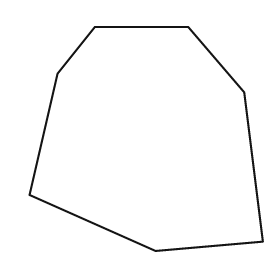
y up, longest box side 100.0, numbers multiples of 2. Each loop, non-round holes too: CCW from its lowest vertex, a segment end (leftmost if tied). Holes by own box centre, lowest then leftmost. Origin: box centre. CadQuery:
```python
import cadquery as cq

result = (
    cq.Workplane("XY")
    .moveTo(4.0, -48.0)
    .lineTo(50.0, -44.0)
    .lineTo(42.0, 20.0)
    .lineTo(18.0, 48.0)
    .lineTo(-22.0, 48.0)
    .lineTo(-38.0, 28.0)
    .lineTo(-50.0, -24.0)
    .close()
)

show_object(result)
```